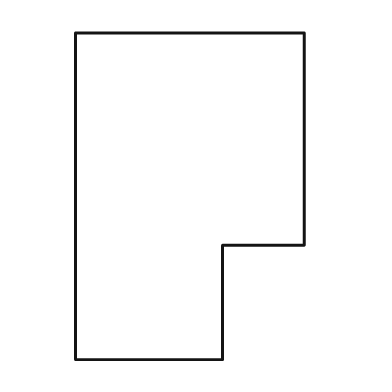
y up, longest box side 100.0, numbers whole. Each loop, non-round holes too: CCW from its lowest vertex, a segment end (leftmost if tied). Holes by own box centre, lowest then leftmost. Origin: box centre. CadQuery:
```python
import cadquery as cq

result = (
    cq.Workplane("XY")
    .moveTo(-35.0, -50.0)
    .lineTo(10.0, -50.0)
    .lineTo(10.0, -15.0)
    .lineTo(35.0, -15.0)
    .lineTo(35.0, 50.0)
    .lineTo(-35.0, 50.0)
    .close()
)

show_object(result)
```